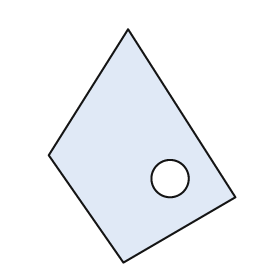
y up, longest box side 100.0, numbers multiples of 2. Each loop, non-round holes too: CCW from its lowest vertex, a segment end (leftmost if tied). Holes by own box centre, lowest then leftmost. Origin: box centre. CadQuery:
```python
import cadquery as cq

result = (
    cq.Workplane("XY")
    .moveTo(-8.0, -50.0)
    .lineTo(40.0, -22.0)
    .lineTo(-6.0, 50.0)
    .lineTo(-40.0, -4.0)
    .close()
    .moveTo(12.0, -14.0)
    .circle(8.0)
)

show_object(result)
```